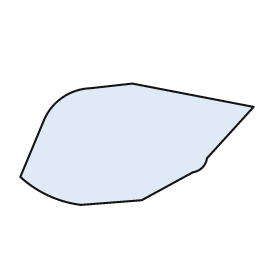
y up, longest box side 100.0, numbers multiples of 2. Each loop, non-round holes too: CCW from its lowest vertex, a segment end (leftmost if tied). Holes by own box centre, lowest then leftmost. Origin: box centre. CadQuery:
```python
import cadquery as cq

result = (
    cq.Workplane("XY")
    .moveTo(-24.0, -26.0)
    .lineTo(2.0, -24.0)
    .lineTo(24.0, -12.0)
    .threePointArc((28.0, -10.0), (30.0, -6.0))
    .lineTo(50.0, 16.0)
    .lineTo(-2.0, 26.0)
    .lineTo(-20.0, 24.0)
    .threePointArc((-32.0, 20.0), (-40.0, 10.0))
    .lineTo(-50.0, -14.0)
    .threePointArc((-38.0, -22.0), (-24.0, -26.0))
    .close()
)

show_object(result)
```